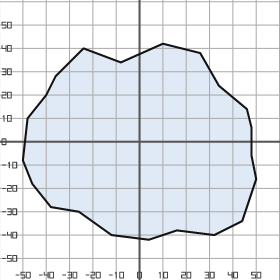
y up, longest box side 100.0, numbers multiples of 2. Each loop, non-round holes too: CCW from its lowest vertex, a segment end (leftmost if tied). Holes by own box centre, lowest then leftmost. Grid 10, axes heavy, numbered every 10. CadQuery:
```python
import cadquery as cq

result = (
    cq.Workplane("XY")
    .moveTo(4.0, -42.0)
    .lineTo(16.0, -38.0)
    .lineTo(32.0, -40.0)
    .lineTo(44.0, -34.0)
    .lineTo(50.0, -16.0)
    .lineTo(48.0, -6.0)
    .lineTo(48.0, 6.0)
    .lineTo(46.0, 14.0)
    .lineTo(34.0, 24.0)
    .lineTo(26.0, 38.0)
    .lineTo(10.0, 42.0)
    .lineTo(-8.0, 34.0)
    .lineTo(-24.0, 40.0)
    .lineTo(-36.0, 28.0)
    .lineTo(-40.0, 20.0)
    .lineTo(-48.0, 10.0)
    .lineTo(-50.0, -8.0)
    .lineTo(-46.0, -18.0)
    .lineTo(-38.0, -28.0)
    .lineTo(-26.0, -30.0)
    .lineTo(-12.0, -40.0)
    .close()
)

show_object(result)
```